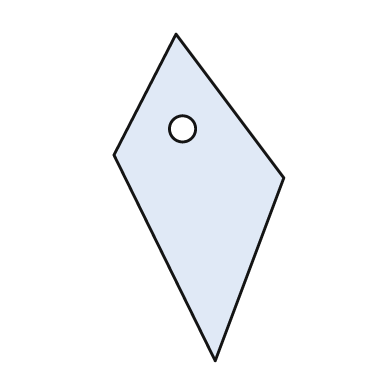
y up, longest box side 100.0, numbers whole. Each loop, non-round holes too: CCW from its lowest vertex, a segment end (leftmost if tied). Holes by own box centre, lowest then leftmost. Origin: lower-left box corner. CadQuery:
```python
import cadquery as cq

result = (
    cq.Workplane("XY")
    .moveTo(31.0, 0.0)
    .lineTo(52.0, 56.0)
    .lineTo(19.0, 100.0)
    .lineTo(0.0, 63.0)
    .close()
    .moveTo(21.0, 71.0)
    .circle(4.0)
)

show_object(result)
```